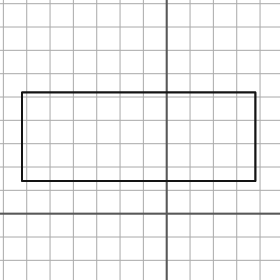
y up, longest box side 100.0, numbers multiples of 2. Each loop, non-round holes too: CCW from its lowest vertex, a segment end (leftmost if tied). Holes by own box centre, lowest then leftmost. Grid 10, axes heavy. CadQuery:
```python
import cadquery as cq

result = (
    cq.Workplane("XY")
    .moveTo(-62.0, 14.0)
    .lineTo(38.0, 14.0)
    .lineTo(38.0, 52.0)
    .lineTo(-62.0, 52.0)
    .close()
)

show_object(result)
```